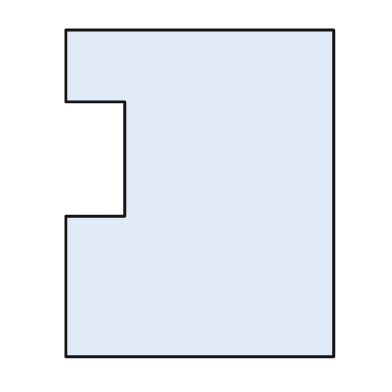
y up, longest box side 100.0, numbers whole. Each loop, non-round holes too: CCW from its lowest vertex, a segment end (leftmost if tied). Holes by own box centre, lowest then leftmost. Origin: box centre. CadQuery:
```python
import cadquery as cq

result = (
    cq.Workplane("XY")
    .moveTo(-41.0, -50.0)
    .lineTo(41.0, -50.0)
    .lineTo(41.0, 50.0)
    .lineTo(-41.0, 50.0)
    .lineTo(-41.0, 28.0)
    .lineTo(-23.0, 28.0)
    .lineTo(-23.0, -7.0)
    .lineTo(-41.0, -7.0)
    .close()
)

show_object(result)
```